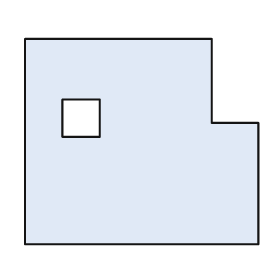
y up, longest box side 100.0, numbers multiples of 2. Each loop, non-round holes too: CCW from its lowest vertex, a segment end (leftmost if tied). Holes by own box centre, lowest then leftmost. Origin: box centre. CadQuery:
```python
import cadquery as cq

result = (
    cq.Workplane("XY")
    .moveTo(-50.0, -44.0)
    .lineTo(50.0, -44.0)
    .lineTo(50.0, 8.0)
    .lineTo(30.0, 8.0)
    .lineTo(30.0, 44.0)
    .lineTo(-50.0, 44.0)
    .close()
    .moveTo(-34.0, 2.0)
    .lineTo(-18.0, 2.0)
    .lineTo(-18.0, 18.0)
    .lineTo(-34.0, 18.0)
    .close()
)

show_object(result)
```